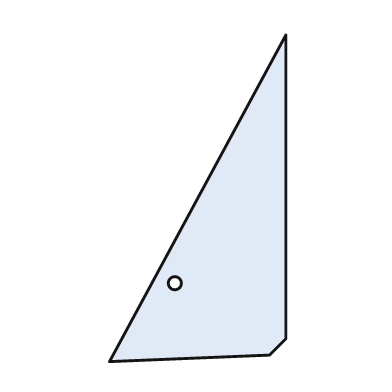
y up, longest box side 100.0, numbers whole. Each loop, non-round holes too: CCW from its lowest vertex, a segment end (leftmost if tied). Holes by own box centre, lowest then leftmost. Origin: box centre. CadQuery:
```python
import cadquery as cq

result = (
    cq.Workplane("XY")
    .moveTo(-27.0, -50.0)
    .lineTo(22.0, -48.0)
    .lineTo(27.0, -43.0)
    .lineTo(27.0, 50.0)
    .close()
    .moveTo(-7.0, -26.0)
    .circle(2.0)
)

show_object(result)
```